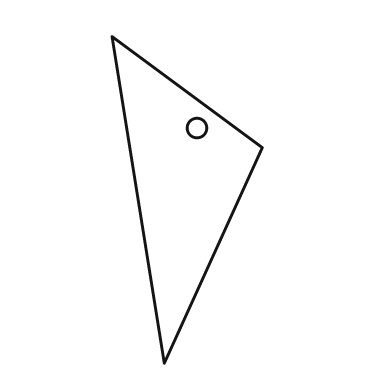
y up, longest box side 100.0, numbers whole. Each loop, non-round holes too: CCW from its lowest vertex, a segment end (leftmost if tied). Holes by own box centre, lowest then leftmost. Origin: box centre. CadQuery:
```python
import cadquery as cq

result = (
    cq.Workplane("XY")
    .moveTo(-7.0, -50.0)
    .lineTo(23.0, 16.0)
    .lineTo(-23.0, 50.0)
    .close()
    .moveTo(3.0, 22.0)
    .circle(3.0)
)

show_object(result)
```